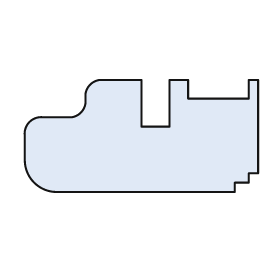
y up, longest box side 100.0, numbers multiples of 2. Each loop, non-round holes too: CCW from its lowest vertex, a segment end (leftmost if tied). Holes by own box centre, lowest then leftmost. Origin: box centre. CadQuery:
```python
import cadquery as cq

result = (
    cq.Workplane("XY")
    .moveTo(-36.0, -24.0)
    .lineTo(40.0, -24.0)
    .lineTo(40.0, -20.0)
    .lineTo(46.0, -20.0)
    .lineTo(46.0, -16.0)
    .lineTo(50.0, -16.0)
    .lineTo(50.0, 24.0)
    .lineTo(46.0, 24.0)
    .lineTo(46.0, 16.0)
    .lineTo(20.0, 16.0)
    .lineTo(20.0, 24.0)
    .lineTo(12.0, 24.0)
    .lineTo(12.0, 4.0)
    .lineTo(0.0, 4.0)
    .lineTo(0.0, 24.0)
    .lineTo(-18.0, 24.0)
    .threePointArc((-22.0, 22.0), (-24.0, 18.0))
    .lineTo(-24.0, 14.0)
    .threePointArc((-26.0, 10.0), (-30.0, 8.0))
    .lineTo(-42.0, 8.0)
    .threePointArc((-48.0, 6.0), (-50.0, 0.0))
    .lineTo(-50.0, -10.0)
    .threePointArc((-46.0, -20.0), (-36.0, -24.0))
    .close()
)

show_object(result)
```